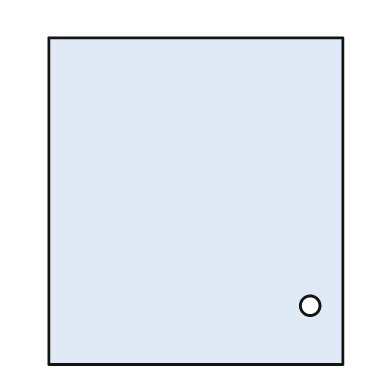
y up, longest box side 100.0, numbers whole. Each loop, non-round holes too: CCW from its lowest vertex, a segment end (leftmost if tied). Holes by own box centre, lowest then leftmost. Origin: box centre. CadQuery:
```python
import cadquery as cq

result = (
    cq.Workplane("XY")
    .moveTo(-45.0, -50.0)
    .lineTo(45.0, -50.0)
    .lineTo(45.0, 50.0)
    .lineTo(-45.0, 50.0)
    .close()
    .moveTo(35.0, -32.0)
    .circle(3.0)
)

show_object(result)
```